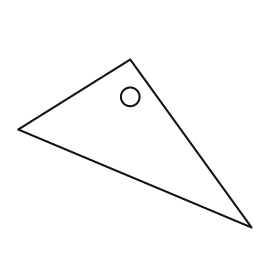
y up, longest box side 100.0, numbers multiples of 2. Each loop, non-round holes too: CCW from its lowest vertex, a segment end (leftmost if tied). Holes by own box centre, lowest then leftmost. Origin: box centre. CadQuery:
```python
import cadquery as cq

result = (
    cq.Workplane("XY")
    .moveTo(50.0, -36.0)
    .lineTo(-2.0, 36.0)
    .lineTo(-50.0, 6.0)
    .close()
    .moveTo(-2.0, 20.0)
    .circle(4.0)
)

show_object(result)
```